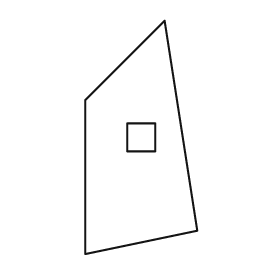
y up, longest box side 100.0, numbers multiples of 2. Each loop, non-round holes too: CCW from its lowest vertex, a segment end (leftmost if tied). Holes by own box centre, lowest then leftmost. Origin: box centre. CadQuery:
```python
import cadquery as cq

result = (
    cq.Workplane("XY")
    .moveTo(-24.0, -50.0)
    .lineTo(24.0, -40.0)
    .lineTo(10.0, 50.0)
    .lineTo(-24.0, 16.0)
    .close()
    .moveTo(-6.0, -6.0)
    .lineTo(6.0, -6.0)
    .lineTo(6.0, 6.0)
    .lineTo(-6.0, 6.0)
    .close()
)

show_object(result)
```